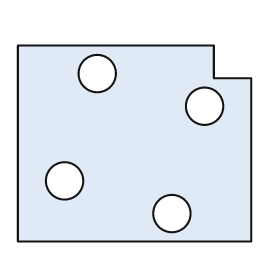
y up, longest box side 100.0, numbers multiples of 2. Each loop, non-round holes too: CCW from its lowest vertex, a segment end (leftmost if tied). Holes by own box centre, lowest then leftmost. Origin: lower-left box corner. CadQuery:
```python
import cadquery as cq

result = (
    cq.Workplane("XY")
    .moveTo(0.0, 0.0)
    .lineTo(100.0, 0.0)
    .lineTo(100.0, 70.0)
    .lineTo(84.0, 70.0)
    .lineTo(84.0, 84.0)
    .lineTo(0.0, 84.0)
    .close()
    .moveTo(66.0, 12.0)
    .circle(8.0)
    .moveTo(20.0, 26.0)
    .circle(8.0)
    .moveTo(80.0, 58.0)
    .circle(8.0)
    .moveTo(34.0, 72.0)
    .circle(8.0)
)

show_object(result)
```